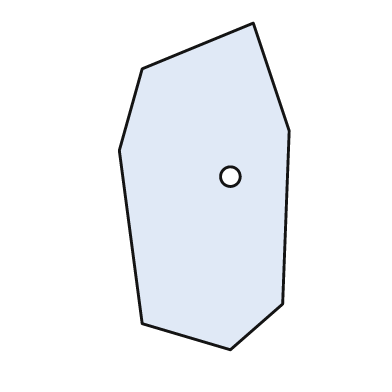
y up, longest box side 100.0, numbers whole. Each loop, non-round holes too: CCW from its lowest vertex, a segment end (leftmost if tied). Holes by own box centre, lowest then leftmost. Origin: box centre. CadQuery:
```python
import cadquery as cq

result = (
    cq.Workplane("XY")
    .moveTo(8.0, -50.0)
    .lineTo(24.0, -36.0)
    .lineTo(26.0, 17.0)
    .lineTo(15.0, 50.0)
    .lineTo(-19.0, 36.0)
    .lineTo(-26.0, 11.0)
    .lineTo(-19.0, -42.0)
    .close()
    .moveTo(8.0, 3.0)
    .circle(3.0)
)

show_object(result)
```